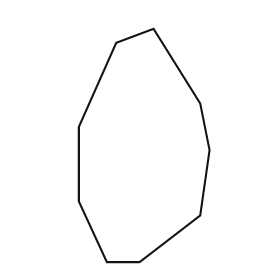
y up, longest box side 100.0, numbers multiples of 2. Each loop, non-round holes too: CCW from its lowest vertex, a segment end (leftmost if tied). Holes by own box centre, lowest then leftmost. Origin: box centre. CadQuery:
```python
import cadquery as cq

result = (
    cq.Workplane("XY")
    .moveTo(-16.0, -50.0)
    .lineTo(-2.0, -50.0)
    .lineTo(24.0, -30.0)
    .lineTo(28.0, -2.0)
    .lineTo(24.0, 18.0)
    .lineTo(4.0, 50.0)
    .lineTo(-12.0, 44.0)
    .lineTo(-28.0, 8.0)
    .lineTo(-28.0, -24.0)
    .close()
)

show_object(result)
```